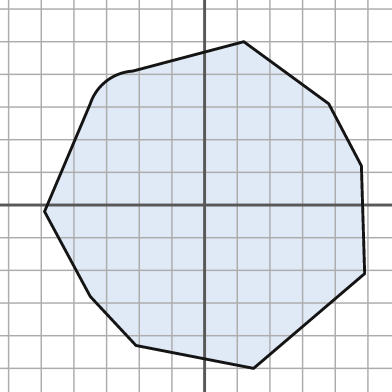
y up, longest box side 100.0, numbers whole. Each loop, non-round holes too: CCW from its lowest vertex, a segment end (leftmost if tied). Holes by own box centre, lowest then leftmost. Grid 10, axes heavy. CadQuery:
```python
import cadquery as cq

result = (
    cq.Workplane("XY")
    .moveTo(15.0, -50.0)
    .lineTo(49.0, -21.0)
    .lineTo(48.0, 12.0)
    .lineTo(38.0, 31.0)
    .lineTo(12.0, 50.0)
    .lineTo(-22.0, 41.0)
    .threePointArc((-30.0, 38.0), (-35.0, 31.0))
    .lineTo(-49.0, -2.0)
    .lineTo(-35.0, -28.0)
    .lineTo(-21.0, -43.0)
    .close()
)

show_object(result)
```